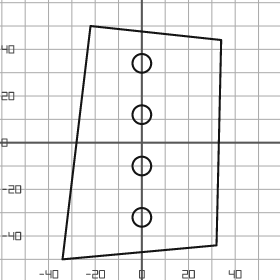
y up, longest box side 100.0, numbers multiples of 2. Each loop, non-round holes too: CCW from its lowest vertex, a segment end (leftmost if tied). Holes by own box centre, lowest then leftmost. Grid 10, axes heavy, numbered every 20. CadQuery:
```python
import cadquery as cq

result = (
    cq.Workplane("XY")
    .moveTo(-34.0, -50.0)
    .lineTo(32.0, -44.0)
    .lineTo(34.0, 44.0)
    .lineTo(-22.0, 50.0)
    .close()
    .moveTo(0.0, -32.0)
    .circle(4.0)
    .moveTo(0.0, -10.0)
    .circle(4.0)
    .moveTo(0.0, 12.0)
    .circle(4.0)
    .moveTo(0.0, 34.0)
    .circle(4.0)
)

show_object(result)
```